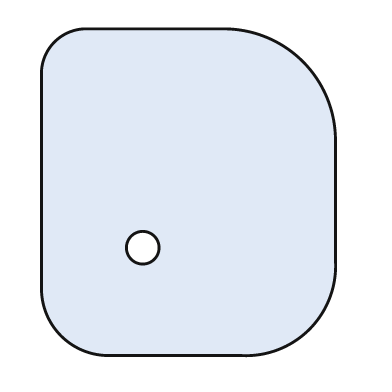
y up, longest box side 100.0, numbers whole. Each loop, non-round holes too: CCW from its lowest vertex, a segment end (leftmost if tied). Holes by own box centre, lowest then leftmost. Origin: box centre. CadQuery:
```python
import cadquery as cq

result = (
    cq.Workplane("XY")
    .moveTo(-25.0, -50.0)
    .lineTo(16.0, -50.0)
    .threePointArc((37.0, -42.0), (45.0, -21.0))
    .lineTo(45.0, 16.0)
    .threePointArc((35.0, 40.0), (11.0, 50.0))
    .lineTo(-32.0, 50.0)
    .threePointArc((-41.0, 46.0), (-45.0, 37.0))
    .lineTo(-45.0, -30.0)
    .threePointArc((-39.0, -44.0), (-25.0, -50.0))
    .close()
    .moveTo(-14.0, -17.0)
    .circle(5.0)
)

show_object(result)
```